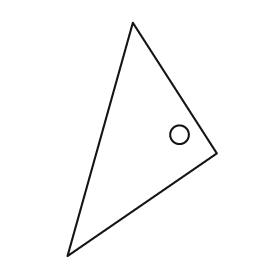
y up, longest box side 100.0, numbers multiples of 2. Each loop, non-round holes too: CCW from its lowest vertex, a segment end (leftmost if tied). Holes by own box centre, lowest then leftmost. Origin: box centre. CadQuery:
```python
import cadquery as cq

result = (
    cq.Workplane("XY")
    .moveTo(-32.0, -50.0)
    .lineTo(32.0, -6.0)
    .lineTo(-4.0, 50.0)
    .close()
    .moveTo(16.0, 2.0)
    .circle(4.0)
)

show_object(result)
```